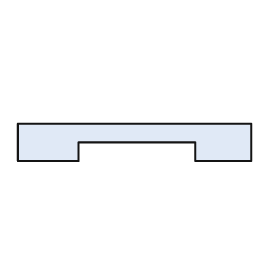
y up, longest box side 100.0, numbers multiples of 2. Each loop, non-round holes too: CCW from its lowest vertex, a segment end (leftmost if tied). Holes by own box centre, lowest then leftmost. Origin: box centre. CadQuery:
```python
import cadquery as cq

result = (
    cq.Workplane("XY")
    .moveTo(-50.0, -8.0)
    .lineTo(-24.0, -8.0)
    .lineTo(-24.0, 0.0)
    .lineTo(26.0, 0.0)
    .lineTo(26.0, -8.0)
    .lineTo(50.0, -8.0)
    .lineTo(50.0, 8.0)
    .lineTo(-50.0, 8.0)
    .close()
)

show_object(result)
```